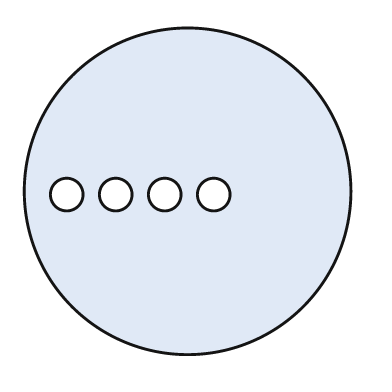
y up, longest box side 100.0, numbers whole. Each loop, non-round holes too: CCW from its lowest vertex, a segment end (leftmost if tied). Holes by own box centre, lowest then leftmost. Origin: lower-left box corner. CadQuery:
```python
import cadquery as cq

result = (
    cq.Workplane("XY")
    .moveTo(50.0, 50.0)
    .circle(50.0)
    .moveTo(13.0, 49.0)
    .circle(5.0)
    .moveTo(28.0, 49.0)
    .circle(5.0)
    .moveTo(43.0, 49.0)
    .circle(5.0)
    .moveTo(58.0, 49.0)
    .circle(5.0)
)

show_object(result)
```